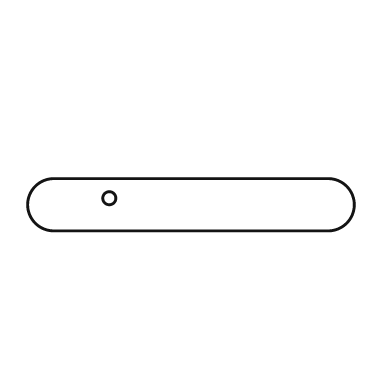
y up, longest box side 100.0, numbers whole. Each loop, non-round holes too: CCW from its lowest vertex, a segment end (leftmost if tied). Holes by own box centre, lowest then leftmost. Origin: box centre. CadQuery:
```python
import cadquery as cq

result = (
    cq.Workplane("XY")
    .moveTo(-42.0, -8.0)
    .lineTo(42.0, -8.0)
    .threePointArc((50.0, 0.0), (42.0, 8.0))
    .lineTo(-42.0, 8.0)
    .threePointArc((-50.0, 0.0), (-42.0, -8.0))
    .close()
    .moveTo(-25.0, 2.0)
    .circle(2.0)
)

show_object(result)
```